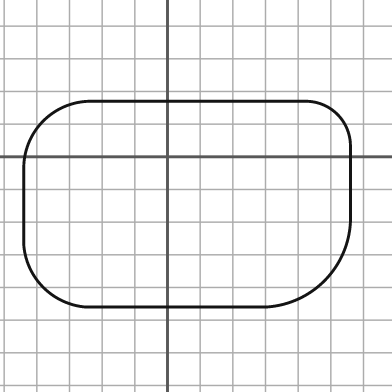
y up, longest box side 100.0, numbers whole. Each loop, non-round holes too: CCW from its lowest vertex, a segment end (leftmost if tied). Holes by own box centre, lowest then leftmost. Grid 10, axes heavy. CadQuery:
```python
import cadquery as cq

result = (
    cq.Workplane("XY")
    .moveTo(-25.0, -46.0)
    .lineTo(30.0, -46.0)
    .threePointArc((48.0, -38.0), (56.0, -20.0))
    .lineTo(56.0, 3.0)
    .threePointArc((52.0, 13.0), (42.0, 17.0))
    .lineTo(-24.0, 17.0)
    .threePointArc((-38.0, 11.0), (-44.0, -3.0))
    .lineTo(-44.0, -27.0)
    .threePointArc((-38.0, -40.0), (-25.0, -46.0))
    .close()
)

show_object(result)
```